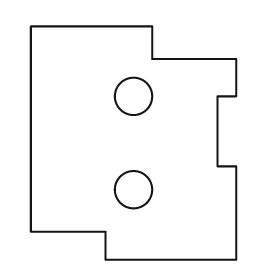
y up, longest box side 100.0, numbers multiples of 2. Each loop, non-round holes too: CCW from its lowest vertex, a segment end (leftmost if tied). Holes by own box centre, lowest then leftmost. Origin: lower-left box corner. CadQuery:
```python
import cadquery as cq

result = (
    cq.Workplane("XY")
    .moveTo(32.0, 0.0)
    .lineTo(88.0, 0.0)
    .lineTo(88.0, 40.0)
    .lineTo(80.0, 40.0)
    .lineTo(80.0, 70.0)
    .lineTo(88.0, 70.0)
    .lineTo(88.0, 86.0)
    .lineTo(52.0, 86.0)
    .lineTo(52.0, 100.0)
    .lineTo(0.0, 100.0)
    .lineTo(0.0, 12.0)
    .lineTo(32.0, 12.0)
    .close()
    .moveTo(44.0, 30.0)
    .circle(8.0)
    .moveTo(44.0, 70.0)
    .circle(8.0)
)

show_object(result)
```